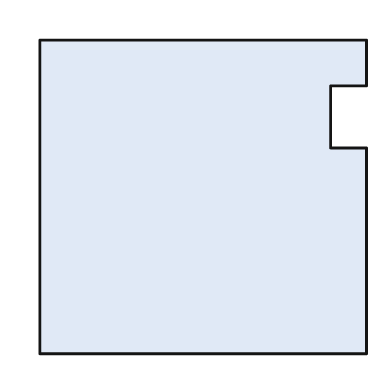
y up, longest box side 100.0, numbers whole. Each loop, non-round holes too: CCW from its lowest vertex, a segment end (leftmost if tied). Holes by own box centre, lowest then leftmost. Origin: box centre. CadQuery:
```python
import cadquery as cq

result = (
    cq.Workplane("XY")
    .moveTo(-50.0, -48.0)
    .lineTo(50.0, -48.0)
    .lineTo(50.0, 15.0)
    .lineTo(39.0, 15.0)
    .lineTo(39.0, 34.0)
    .lineTo(50.0, 34.0)
    .lineTo(50.0, 48.0)
    .lineTo(-50.0, 48.0)
    .close()
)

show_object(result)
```